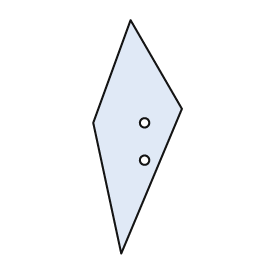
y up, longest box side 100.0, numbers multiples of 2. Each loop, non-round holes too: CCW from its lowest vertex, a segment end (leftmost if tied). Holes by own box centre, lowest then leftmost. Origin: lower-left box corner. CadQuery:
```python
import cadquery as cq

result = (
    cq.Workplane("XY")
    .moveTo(12.0, 0.0)
    .lineTo(38.0, 62.0)
    .lineTo(16.0, 100.0)
    .lineTo(0.0, 56.0)
    .close()
    .moveTo(22.0, 40.0)
    .circle(2.0)
    .moveTo(22.0, 56.0)
    .circle(2.0)
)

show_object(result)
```